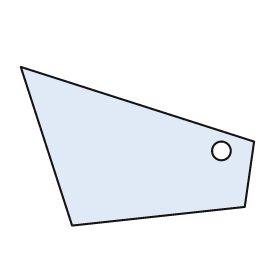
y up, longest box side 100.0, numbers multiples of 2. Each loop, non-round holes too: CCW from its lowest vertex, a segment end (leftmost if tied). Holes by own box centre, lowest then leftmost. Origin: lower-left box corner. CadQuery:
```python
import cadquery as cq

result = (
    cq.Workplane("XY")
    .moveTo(22.0, 0.0)
    .lineTo(96.0, 8.0)
    .lineTo(100.0, 36.0)
    .lineTo(0.0, 68.0)
    .close()
    .moveTo(86.0, 32.0)
    .circle(4.0)
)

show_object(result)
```